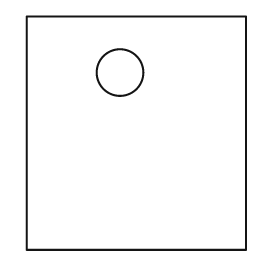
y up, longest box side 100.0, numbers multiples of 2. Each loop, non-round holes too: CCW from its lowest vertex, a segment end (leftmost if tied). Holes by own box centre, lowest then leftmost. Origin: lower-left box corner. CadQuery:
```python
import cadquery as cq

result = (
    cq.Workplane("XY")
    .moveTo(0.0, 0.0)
    .lineTo(94.0, 0.0)
    .lineTo(94.0, 100.0)
    .lineTo(0.0, 100.0)
    .close()
    .moveTo(40.0, 76.0)
    .circle(10.0)
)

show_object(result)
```